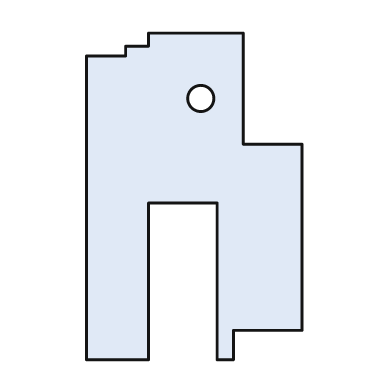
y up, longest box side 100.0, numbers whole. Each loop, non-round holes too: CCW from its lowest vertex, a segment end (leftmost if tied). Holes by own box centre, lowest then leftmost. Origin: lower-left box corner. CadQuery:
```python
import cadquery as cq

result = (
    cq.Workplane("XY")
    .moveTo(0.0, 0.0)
    .lineTo(19.0, 0.0)
    .lineTo(19.0, 48.0)
    .lineTo(40.0, 48.0)
    .lineTo(40.0, 0.0)
    .lineTo(45.0, 0.0)
    .lineTo(45.0, 9.0)
    .lineTo(66.0, 9.0)
    .lineTo(66.0, 66.0)
    .lineTo(48.0, 66.0)
    .lineTo(48.0, 100.0)
    .lineTo(19.0, 100.0)
    .lineTo(19.0, 96.0)
    .lineTo(12.0, 96.0)
    .lineTo(12.0, 93.0)
    .lineTo(0.0, 93.0)
    .close()
    .moveTo(35.0, 80.0)
    .circle(4.0)
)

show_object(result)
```